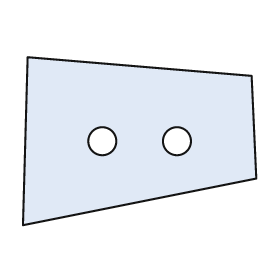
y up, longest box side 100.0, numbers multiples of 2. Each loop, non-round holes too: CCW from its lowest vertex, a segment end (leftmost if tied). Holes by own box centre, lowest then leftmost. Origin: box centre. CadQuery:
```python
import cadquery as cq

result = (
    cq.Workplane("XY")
    .moveTo(-50.0, -36.0)
    .lineTo(50.0, -16.0)
    .lineTo(48.0, 28.0)
    .lineTo(-48.0, 36.0)
    .close()
    .moveTo(-16.0, 0.0)
    .circle(6.0)
    .moveTo(16.0, 0.0)
    .circle(6.0)
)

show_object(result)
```